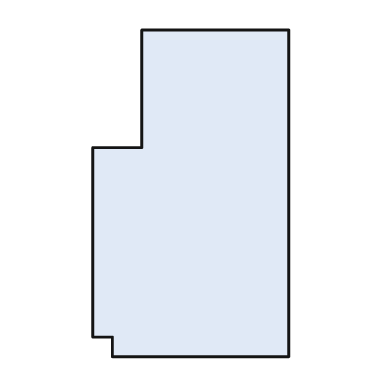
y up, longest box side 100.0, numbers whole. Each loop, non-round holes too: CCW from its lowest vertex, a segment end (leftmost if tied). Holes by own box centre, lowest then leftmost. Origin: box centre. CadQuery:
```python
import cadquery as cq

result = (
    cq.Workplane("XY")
    .moveTo(-24.0, -50.0)
    .lineTo(30.0, -50.0)
    .lineTo(30.0, 50.0)
    .lineTo(-15.0, 50.0)
    .lineTo(-15.0, 14.0)
    .lineTo(-30.0, 14.0)
    .lineTo(-30.0, -44.0)
    .lineTo(-24.0, -44.0)
    .close()
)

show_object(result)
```